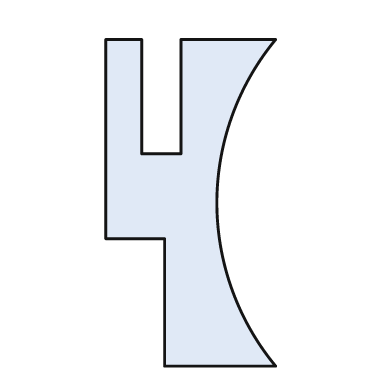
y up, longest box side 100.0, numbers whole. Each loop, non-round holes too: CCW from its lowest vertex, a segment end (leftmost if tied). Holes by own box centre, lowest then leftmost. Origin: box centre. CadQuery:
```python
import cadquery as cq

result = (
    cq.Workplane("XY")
    .moveTo(-8.0, -50.0)
    .lineTo(26.0, -50.0)
    .threePointArc((8.0, 0.0), (26.0, 50.0))
    .lineTo(-3.0, 50.0)
    .lineTo(-3.0, 15.0)
    .lineTo(-15.0, 15.0)
    .lineTo(-15.0, 50.0)
    .lineTo(-26.0, 50.0)
    .lineTo(-26.0, -11.0)
    .lineTo(-8.0, -11.0)
    .close()
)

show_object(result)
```